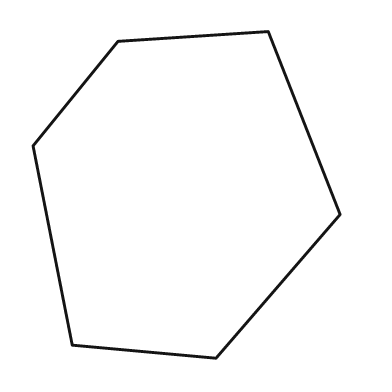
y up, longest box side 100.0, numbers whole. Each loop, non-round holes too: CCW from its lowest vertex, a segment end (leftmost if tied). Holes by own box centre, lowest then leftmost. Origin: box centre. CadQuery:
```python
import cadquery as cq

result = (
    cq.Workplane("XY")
    .moveTo(9.0, -50.0)
    .lineTo(47.0, -6.0)
    .lineTo(25.0, 50.0)
    .lineTo(-21.0, 47.0)
    .lineTo(-47.0, 15.0)
    .lineTo(-35.0, -46.0)
    .close()
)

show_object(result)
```